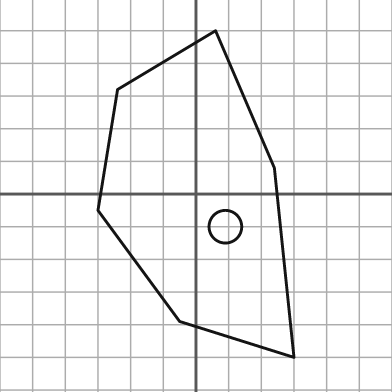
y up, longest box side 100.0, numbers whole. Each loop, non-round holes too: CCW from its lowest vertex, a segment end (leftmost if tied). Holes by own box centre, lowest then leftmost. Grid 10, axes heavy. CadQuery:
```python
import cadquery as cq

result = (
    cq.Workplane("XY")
    .moveTo(30.0, -50.0)
    .lineTo(24.0, 8.0)
    .lineTo(6.0, 50.0)
    .lineTo(-24.0, 32.0)
    .lineTo(-30.0, -5.0)
    .lineTo(-5.0, -39.0)
    .close()
    .moveTo(9.0, -10.0)
    .circle(5.0)
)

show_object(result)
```